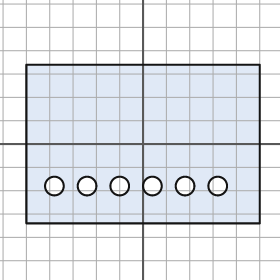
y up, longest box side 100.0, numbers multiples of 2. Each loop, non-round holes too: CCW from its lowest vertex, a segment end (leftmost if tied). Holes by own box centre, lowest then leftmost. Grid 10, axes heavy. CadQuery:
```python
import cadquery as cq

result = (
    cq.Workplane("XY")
    .moveTo(-50.0, -34.0)
    .lineTo(50.0, -34.0)
    .lineTo(50.0, 34.0)
    .lineTo(-50.0, 34.0)
    .close()
    .moveTo(-38.0, -18.0)
    .circle(4.0)
    .moveTo(-24.0, -18.0)
    .circle(4.0)
    .moveTo(-10.0, -18.0)
    .circle(4.0)
    .moveTo(4.0, -18.0)
    .circle(4.0)
    .moveTo(18.0, -18.0)
    .circle(4.0)
    .moveTo(32.0, -18.0)
    .circle(4.0)
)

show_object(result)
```